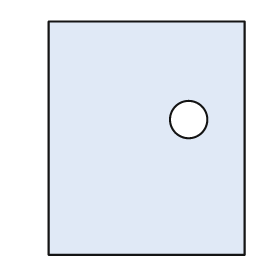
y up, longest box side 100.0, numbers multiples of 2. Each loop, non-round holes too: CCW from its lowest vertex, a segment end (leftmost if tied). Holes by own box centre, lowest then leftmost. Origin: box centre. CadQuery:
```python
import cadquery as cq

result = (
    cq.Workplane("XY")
    .moveTo(-42.0, -50.0)
    .lineTo(42.0, -50.0)
    .lineTo(42.0, 50.0)
    .lineTo(-42.0, 50.0)
    .close()
    .moveTo(18.0, 8.0)
    .circle(8.0)
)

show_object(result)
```